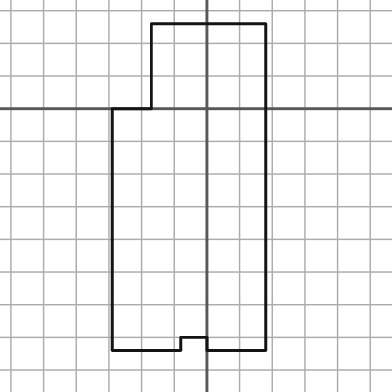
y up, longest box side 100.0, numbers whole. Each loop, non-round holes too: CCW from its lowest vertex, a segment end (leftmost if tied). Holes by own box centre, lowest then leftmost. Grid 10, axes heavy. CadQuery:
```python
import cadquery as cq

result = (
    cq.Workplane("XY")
    .moveTo(-29.0, -74.0)
    .lineTo(-8.0, -74.0)
    .lineTo(-8.0, -70.0)
    .lineTo(0.0, -70.0)
    .lineTo(0.0, -74.0)
    .lineTo(18.0, -74.0)
    .lineTo(18.0, 26.0)
    .lineTo(-17.0, 26.0)
    .lineTo(-17.0, 0.0)
    .lineTo(-29.0, 0.0)
    .close()
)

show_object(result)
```